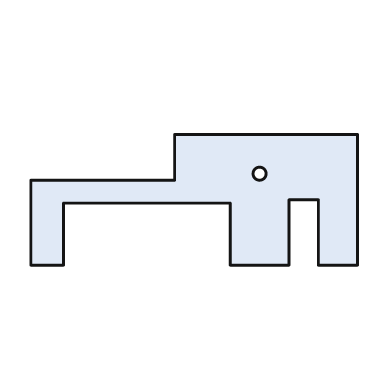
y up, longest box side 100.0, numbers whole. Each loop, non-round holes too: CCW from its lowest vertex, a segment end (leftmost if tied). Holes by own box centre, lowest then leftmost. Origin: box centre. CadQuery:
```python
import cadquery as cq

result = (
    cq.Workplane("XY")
    .moveTo(-50.0, -20.0)
    .lineTo(-40.0, -20.0)
    .lineTo(-40.0, -1.0)
    .lineTo(11.0, -1.0)
    .lineTo(11.0, -20.0)
    .lineTo(29.0, -20.0)
    .lineTo(29.0, 0.0)
    .lineTo(38.0, 0.0)
    .lineTo(38.0, -20.0)
    .lineTo(50.0, -20.0)
    .lineTo(50.0, 20.0)
    .lineTo(-6.0, 20.0)
    .lineTo(-6.0, 6.0)
    .lineTo(-50.0, 6.0)
    .close()
    .moveTo(20.0, 8.0)
    .circle(2.0)
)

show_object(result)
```